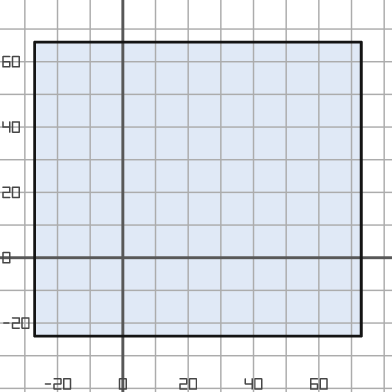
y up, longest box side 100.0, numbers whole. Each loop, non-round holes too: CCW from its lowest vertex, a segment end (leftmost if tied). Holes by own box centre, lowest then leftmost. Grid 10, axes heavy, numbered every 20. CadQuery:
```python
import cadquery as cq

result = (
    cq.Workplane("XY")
    .moveTo(-27.0, -24.0)
    .lineTo(73.0, -24.0)
    .lineTo(73.0, 66.0)
    .lineTo(-27.0, 66.0)
    .close()
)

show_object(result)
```